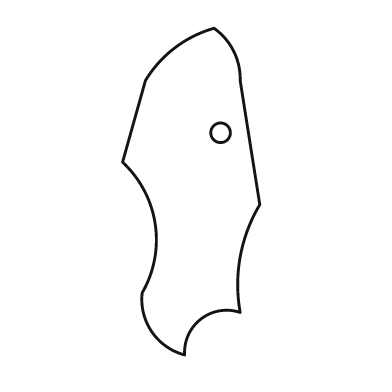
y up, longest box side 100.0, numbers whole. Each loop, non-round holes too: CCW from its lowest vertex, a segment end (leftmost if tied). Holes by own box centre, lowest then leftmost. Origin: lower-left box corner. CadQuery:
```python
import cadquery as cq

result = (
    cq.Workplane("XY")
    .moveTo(19.0, 0.0)
    .threePointArc((24.0, 11.0), (36.0, 13.0))
    .threePointArc((36.0, 30.0), (42.0, 46.0))
    .lineTo(36.0, 84.0)
    .threePointArc((34.0, 93.0), (28.0, 100.0))
    .threePointArc((16.0, 94.0), (7.0, 84.0))
    .lineTo(0.0, 59.0)
    .threePointArc((10.0, 40.0), (6.0, 19.0))
    .threePointArc((9.0, 7.0), (19.0, 0.0))
    .close()
    .moveTo(30.0, 68.0)
    .circle(3.0)
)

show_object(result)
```